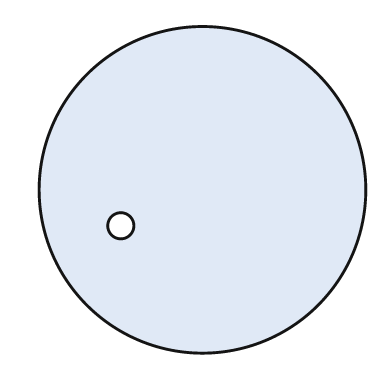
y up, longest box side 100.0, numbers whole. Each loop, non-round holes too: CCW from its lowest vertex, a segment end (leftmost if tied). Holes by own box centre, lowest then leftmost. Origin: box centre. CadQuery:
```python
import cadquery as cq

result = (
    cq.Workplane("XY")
    .moveTo(0.0, 0.0)
    .circle(50.0)
    .moveTo(-25.0, -11.0)
    .circle(4.0)
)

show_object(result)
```